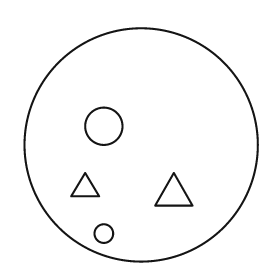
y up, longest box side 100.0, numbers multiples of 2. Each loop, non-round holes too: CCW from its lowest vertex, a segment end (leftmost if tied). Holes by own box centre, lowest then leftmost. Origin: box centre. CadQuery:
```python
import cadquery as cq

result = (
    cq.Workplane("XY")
    .moveTo(0.0, 0.0)
    .circle(50.0)
    .moveTo(-16.0, -38.0)
    .circle(4.0)
    .moveTo(6.0, -26.0)
    .lineTo(22.0, -26.0)
    .lineTo(14.0, -12.0)
    .close()
    .moveTo(-30.0, -22.0)
    .lineTo(-18.0, -22.0)
    .lineTo(-24.0, -12.0)
    .close()
    .moveTo(-16.0, 8.0)
    .circle(8.0)
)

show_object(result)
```